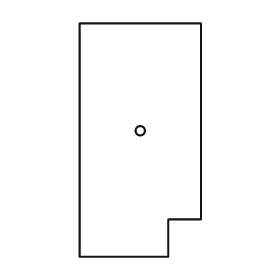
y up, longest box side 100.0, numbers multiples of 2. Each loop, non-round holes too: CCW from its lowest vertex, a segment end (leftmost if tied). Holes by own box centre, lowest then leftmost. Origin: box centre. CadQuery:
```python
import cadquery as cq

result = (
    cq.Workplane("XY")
    .moveTo(-26.0, -50.0)
    .lineTo(12.0, -50.0)
    .lineTo(12.0, -34.0)
    .lineTo(26.0, -34.0)
    .lineTo(26.0, 50.0)
    .lineTo(-26.0, 50.0)
    .close()
    .moveTo(0.0, 4.0)
    .circle(2.0)
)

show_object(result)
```